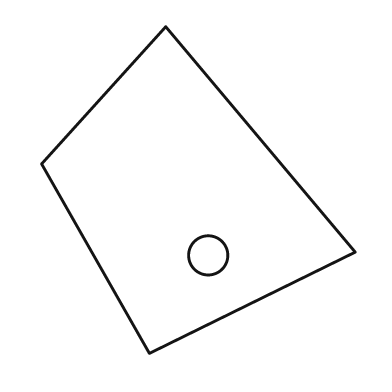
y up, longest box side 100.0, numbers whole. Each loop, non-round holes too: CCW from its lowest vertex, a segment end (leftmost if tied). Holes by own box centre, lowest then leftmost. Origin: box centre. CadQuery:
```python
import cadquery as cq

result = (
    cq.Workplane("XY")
    .moveTo(-15.0, -50.0)
    .lineTo(48.0, -19.0)
    .lineTo(-10.0, 50.0)
    .lineTo(-48.0, 8.0)
    .close()
    .moveTo(3.0, -20.0)
    .circle(6.0)
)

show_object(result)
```